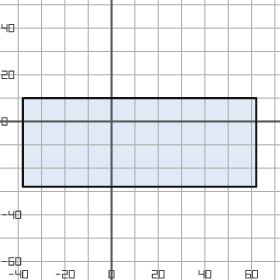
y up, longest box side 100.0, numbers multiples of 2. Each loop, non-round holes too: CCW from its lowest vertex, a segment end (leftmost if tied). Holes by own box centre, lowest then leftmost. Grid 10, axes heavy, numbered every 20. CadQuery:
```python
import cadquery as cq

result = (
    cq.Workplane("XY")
    .moveTo(-38.0, -28.0)
    .lineTo(62.0, -28.0)
    .lineTo(62.0, 10.0)
    .lineTo(-38.0, 10.0)
    .close()
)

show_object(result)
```